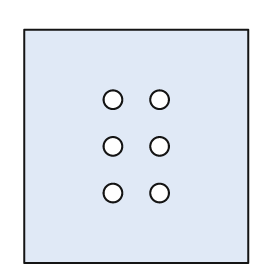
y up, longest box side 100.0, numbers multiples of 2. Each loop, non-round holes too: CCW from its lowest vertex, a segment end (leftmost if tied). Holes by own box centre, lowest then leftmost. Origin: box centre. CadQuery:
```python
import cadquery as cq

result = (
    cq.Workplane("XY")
    .moveTo(-48.0, -50.0)
    .lineTo(48.0, -50.0)
    .lineTo(48.0, 50.0)
    .lineTo(-48.0, 50.0)
    .close()
    .moveTo(-10.0, -20.0)
    .circle(4.0)
    .moveTo(10.0, -20.0)
    .circle(4.0)
    .moveTo(-10.0, 0.0)
    .circle(4.0)
    .moveTo(10.0, 0.0)
    .circle(4.0)
    .moveTo(-10.0, 20.0)
    .circle(4.0)
    .moveTo(10.0, 20.0)
    .circle(4.0)
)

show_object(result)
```